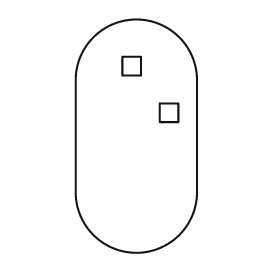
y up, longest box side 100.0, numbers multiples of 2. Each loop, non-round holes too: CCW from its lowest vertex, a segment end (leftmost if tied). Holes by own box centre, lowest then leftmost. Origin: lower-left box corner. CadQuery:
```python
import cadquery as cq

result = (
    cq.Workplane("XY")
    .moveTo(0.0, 26.0)
    .threePointArc((26.0, 0.0), (52.0, 26.0))
    .lineTo(52.0, 74.0)
    .threePointArc((26.0, 100.0), (0.0, 74.0))
    .close()
    .moveTo(36.0, 56.0)
    .lineTo(44.0, 56.0)
    .lineTo(44.0, 64.0)
    .lineTo(36.0, 64.0)
    .close()
    .moveTo(20.0, 76.0)
    .lineTo(28.0, 76.0)
    .lineTo(28.0, 84.0)
    .lineTo(20.0, 84.0)
    .close()
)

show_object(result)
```